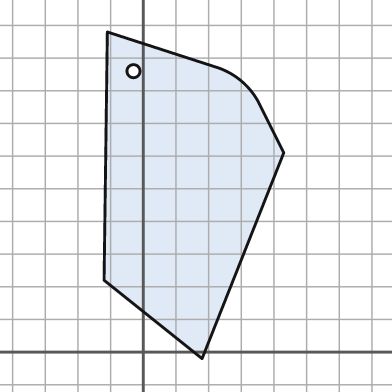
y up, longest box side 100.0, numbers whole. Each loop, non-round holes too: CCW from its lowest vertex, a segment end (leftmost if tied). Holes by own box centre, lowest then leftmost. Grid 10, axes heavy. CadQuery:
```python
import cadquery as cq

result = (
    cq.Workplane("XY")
    .moveTo(18.0, -2.0)
    .lineTo(43.0, 61.0)
    .lineTo(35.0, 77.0)
    .threePointArc((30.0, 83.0), (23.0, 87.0))
    .lineTo(-11.0, 98.0)
    .lineTo(-12.0, 22.0)
    .close()
    .moveTo(-3.0, 86.0)
    .circle(2.0)
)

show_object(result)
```